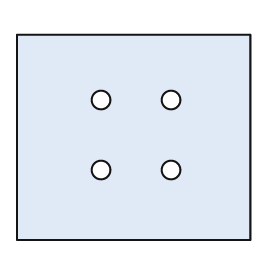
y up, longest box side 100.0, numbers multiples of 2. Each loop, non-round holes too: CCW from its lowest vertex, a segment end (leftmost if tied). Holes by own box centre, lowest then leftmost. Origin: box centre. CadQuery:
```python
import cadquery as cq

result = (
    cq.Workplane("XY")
    .moveTo(-50.0, -44.0)
    .lineTo(50.0, -44.0)
    .lineTo(50.0, 44.0)
    .lineTo(-50.0, 44.0)
    .close()
    .moveTo(-14.0, -14.0)
    .circle(4.0)
    .moveTo(16.0, -14.0)
    .circle(4.0)
    .moveTo(-14.0, 16.0)
    .circle(4.0)
    .moveTo(16.0, 16.0)
    .circle(4.0)
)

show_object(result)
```